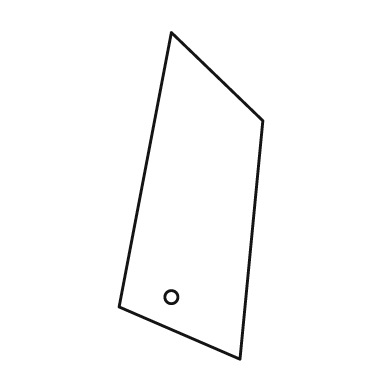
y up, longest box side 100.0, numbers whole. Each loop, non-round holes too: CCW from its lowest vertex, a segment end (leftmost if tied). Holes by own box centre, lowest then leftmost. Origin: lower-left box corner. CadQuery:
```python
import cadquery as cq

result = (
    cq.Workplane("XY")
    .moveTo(37.0, 0.0)
    .lineTo(44.0, 73.0)
    .lineTo(16.0, 100.0)
    .lineTo(0.0, 16.0)
    .close()
    .moveTo(16.0, 19.0)
    .circle(2.0)
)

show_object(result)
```